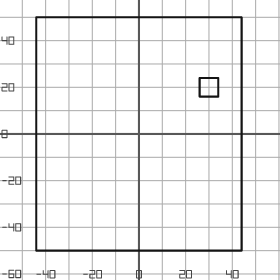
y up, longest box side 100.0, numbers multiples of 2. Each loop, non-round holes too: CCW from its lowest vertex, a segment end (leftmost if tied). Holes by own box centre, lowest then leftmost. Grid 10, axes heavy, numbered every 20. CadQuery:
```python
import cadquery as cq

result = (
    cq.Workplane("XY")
    .moveTo(-44.0, -50.0)
    .lineTo(44.0, -50.0)
    .lineTo(44.0, 50.0)
    .lineTo(-44.0, 50.0)
    .close()
    .moveTo(26.0, 16.0)
    .lineTo(34.0, 16.0)
    .lineTo(34.0, 24.0)
    .lineTo(26.0, 24.0)
    .close()
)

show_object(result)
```